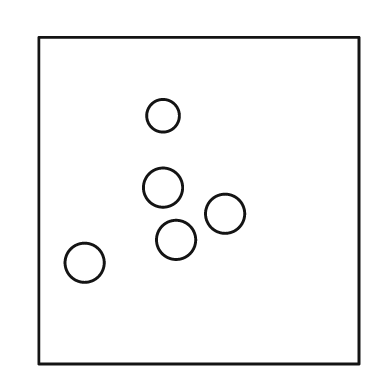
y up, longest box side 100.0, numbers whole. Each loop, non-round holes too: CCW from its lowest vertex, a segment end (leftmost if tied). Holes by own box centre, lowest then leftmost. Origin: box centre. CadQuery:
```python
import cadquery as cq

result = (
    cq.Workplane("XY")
    .moveTo(-49.0, -50.0)
    .lineTo(49.0, -50.0)
    .lineTo(49.0, 50.0)
    .lineTo(-49.0, 50.0)
    .close()
    .moveTo(-35.0, -19.0)
    .circle(6.0)
    .moveTo(-7.0, -12.0)
    .circle(6.0)
    .moveTo(8.0, -4.0)
    .circle(6.0)
    .moveTo(-11.0, 4.0)
    .circle(6.0)
    .moveTo(-11.0, 26.0)
    .circle(5.0)
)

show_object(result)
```